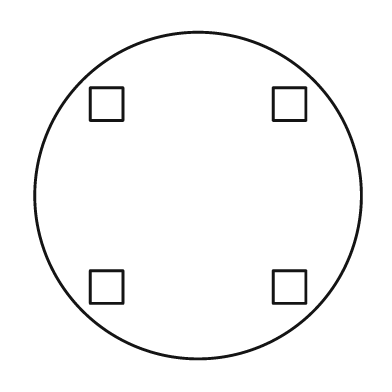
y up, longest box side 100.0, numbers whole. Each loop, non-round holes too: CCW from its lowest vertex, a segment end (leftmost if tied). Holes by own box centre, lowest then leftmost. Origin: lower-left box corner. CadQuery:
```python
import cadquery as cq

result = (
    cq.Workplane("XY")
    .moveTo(50.0, 50.0)
    .circle(50.0)
    .moveTo(17.0, 17.0)
    .lineTo(27.0, 17.0)
    .lineTo(27.0, 27.0)
    .lineTo(17.0, 27.0)
    .close()
    .moveTo(73.0, 17.0)
    .lineTo(83.0, 17.0)
    .lineTo(83.0, 27.0)
    .lineTo(73.0, 27.0)
    .close()
    .moveTo(17.0, 73.0)
    .lineTo(27.0, 73.0)
    .lineTo(27.0, 83.0)
    .lineTo(17.0, 83.0)
    .close()
    .moveTo(73.0, 73.0)
    .lineTo(83.0, 73.0)
    .lineTo(83.0, 83.0)
    .lineTo(73.0, 83.0)
    .close()
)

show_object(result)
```